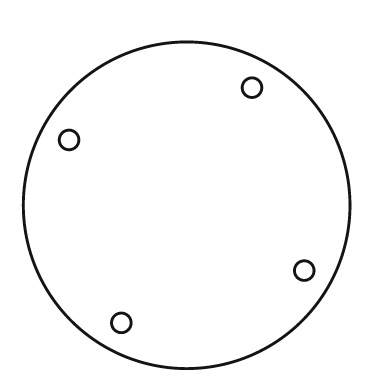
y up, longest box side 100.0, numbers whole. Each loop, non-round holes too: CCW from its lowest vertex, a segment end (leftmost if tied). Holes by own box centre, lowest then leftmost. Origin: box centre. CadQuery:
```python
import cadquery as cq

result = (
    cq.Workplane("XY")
    .moveTo(0.0, 0.0)
    .circle(50.0)
    .moveTo(-20.0, -36.0)
    .circle(3.0)
    .moveTo(36.0, -20.0)
    .circle(3.0)
    .moveTo(-36.0, 20.0)
    .circle(3.0)
    .moveTo(20.0, 36.0)
    .circle(3.0)
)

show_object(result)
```